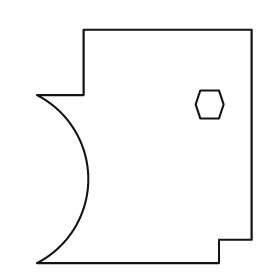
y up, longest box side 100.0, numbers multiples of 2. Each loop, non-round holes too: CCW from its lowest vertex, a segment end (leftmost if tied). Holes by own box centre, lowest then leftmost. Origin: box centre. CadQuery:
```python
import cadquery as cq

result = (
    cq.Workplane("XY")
    .moveTo(-46.0, -50.0)
    .lineTo(32.0, -50.0)
    .lineTo(32.0, -40.0)
    .lineTo(46.0, -40.0)
    .lineTo(46.0, 50.0)
    .lineTo(-26.0, 50.0)
    .lineTo(-26.0, 22.0)
    .lineTo(-46.0, 22.0)
    .threePointArc((-24.0, -14.0), (-46.0, -50.0))
    .close()
    .moveTo(24.0, 12.0)
    .lineTo(32.0, 12.0)
    .lineTo(34.0, 18.0)
    .lineTo(32.0, 24.0)
    .lineTo(24.0, 24.0)
    .lineTo(22.0, 18.0)
    .close()
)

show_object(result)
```